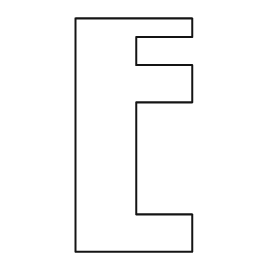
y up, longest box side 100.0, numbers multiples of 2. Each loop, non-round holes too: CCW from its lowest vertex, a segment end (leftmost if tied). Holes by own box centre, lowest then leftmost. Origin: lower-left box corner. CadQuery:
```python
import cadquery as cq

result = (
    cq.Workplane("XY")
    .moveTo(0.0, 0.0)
    .lineTo(50.0, 0.0)
    .lineTo(50.0, 16.0)
    .lineTo(26.0, 16.0)
    .lineTo(26.0, 64.0)
    .lineTo(50.0, 64.0)
    .lineTo(50.0, 80.0)
    .lineTo(26.0, 80.0)
    .lineTo(26.0, 92.0)
    .lineTo(50.0, 92.0)
    .lineTo(50.0, 100.0)
    .lineTo(0.0, 100.0)
    .close()
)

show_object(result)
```